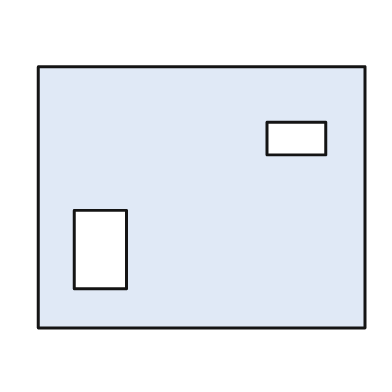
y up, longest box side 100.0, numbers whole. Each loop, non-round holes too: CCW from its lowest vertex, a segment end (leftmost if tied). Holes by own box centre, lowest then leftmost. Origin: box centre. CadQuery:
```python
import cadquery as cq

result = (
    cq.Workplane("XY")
    .moveTo(-50.0, -40.0)
    .lineTo(50.0, -40.0)
    .lineTo(50.0, 40.0)
    .lineTo(-50.0, 40.0)
    .close()
    .moveTo(-39.0, -28.0)
    .lineTo(-23.0, -28.0)
    .lineTo(-23.0, -4.0)
    .lineTo(-39.0, -4.0)
    .close()
    .moveTo(20.0, 13.0)
    .lineTo(38.0, 13.0)
    .lineTo(38.0, 23.0)
    .lineTo(20.0, 23.0)
    .close()
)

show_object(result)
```